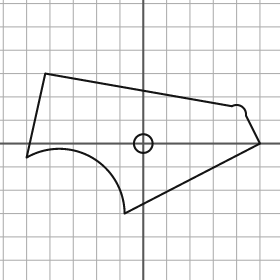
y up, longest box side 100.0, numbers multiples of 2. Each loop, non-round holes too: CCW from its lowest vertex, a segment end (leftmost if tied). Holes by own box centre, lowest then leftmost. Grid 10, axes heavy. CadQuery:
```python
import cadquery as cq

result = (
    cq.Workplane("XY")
    .moveTo(-8.0, -30.0)
    .lineTo(50.0, 0.0)
    .lineTo(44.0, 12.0)
    .threePointArc((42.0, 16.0), (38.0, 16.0))
    .lineTo(-42.0, 30.0)
    .lineTo(-50.0, -6.0)
    .threePointArc((-22.0, -6.0), (-8.0, -30.0))
    .close()
    .moveTo(0.0, 0.0)
    .circle(4.0)
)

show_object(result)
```